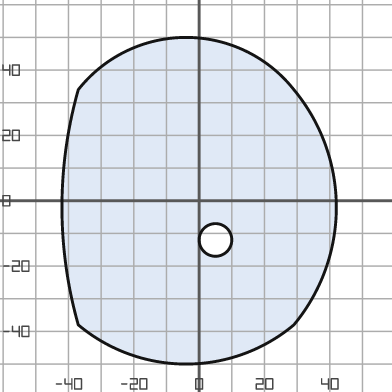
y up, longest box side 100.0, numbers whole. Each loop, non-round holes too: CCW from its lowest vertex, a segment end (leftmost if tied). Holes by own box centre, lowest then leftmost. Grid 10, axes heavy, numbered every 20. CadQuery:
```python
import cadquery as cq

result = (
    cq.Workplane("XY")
    .moveTo(-37.0, -38.0)
    .threePointArc((-4.0, -50.0), (29.0, -38.0))
    .threePointArc((42.0, -2.0), (29.0, 34.0))
    .threePointArc((-4.0, 50.0), (-37.0, 34.0))
    .threePointArc((-42.0, -2.0), (-37.0, -38.0))
    .close()
    .moveTo(5.0, -12.0)
    .circle(5.0)
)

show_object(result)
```